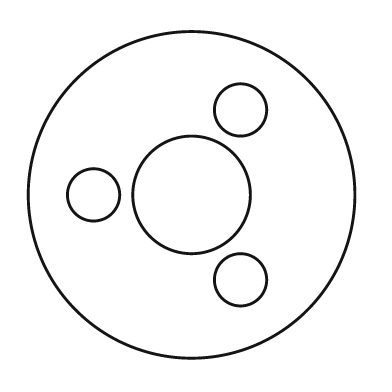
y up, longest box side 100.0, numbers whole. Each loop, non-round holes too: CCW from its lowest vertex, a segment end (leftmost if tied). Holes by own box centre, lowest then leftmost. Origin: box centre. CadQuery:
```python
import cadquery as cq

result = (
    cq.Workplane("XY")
    .moveTo(0.0, 0.0)
    .circle(50.0)
    .moveTo(15.0, -26.0)
    .circle(8.0)
    .moveTo(-30.0, 0.0)
    .circle(8.0)
    .moveTo(0.0, 0.0)
    .circle(18.0)
    .moveTo(15.0, 26.0)
    .circle(8.0)
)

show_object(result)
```